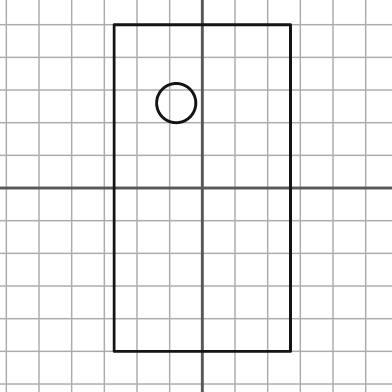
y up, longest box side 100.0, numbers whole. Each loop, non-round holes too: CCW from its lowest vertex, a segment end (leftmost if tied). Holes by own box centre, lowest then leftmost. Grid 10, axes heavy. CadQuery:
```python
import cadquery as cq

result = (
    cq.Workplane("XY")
    .moveTo(-27.0, -50.0)
    .lineTo(27.0, -50.0)
    .lineTo(27.0, 50.0)
    .lineTo(-27.0, 50.0)
    .close()
    .moveTo(-8.0, 26.0)
    .circle(6.0)
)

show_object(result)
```